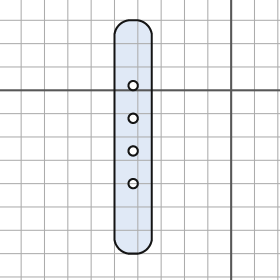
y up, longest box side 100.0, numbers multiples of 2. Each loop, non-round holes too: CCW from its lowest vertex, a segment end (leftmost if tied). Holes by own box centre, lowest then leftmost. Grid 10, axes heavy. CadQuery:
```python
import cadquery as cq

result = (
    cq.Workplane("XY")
    .moveTo(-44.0, -70.0)
    .lineTo(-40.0, -70.0)
    .threePointArc((-36.0, -68.0), (-34.0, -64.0))
    .lineTo(-34.0, 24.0)
    .threePointArc((-36.0, 28.0), (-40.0, 30.0))
    .lineTo(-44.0, 30.0)
    .threePointArc((-48.0, 28.0), (-50.0, 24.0))
    .lineTo(-50.0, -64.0)
    .threePointArc((-48.0, -68.0), (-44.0, -70.0))
    .close()
    .moveTo(-42.0, -40.0)
    .circle(2.0)
    .moveTo(-42.0, -26.0)
    .circle(2.0)
    .moveTo(-42.0, -12.0)
    .circle(2.0)
    .moveTo(-42.0, 2.0)
    .circle(2.0)
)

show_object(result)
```